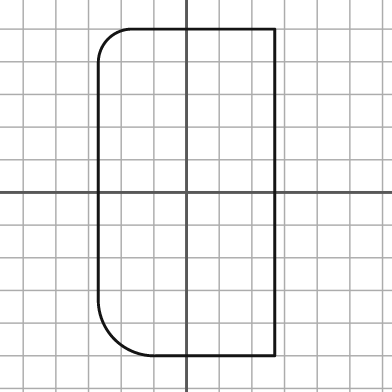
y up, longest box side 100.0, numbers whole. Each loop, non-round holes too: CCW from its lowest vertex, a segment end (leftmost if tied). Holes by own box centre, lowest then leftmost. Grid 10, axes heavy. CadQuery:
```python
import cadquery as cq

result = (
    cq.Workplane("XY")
    .moveTo(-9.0, -50.0)
    .lineTo(27.0, -50.0)
    .lineTo(27.0, 50.0)
    .lineTo(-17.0, 50.0)
    .threePointArc((-24.0, 47.0), (-27.0, 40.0))
    .lineTo(-27.0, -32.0)
    .threePointArc((-22.0, -45.0), (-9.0, -50.0))
    .close()
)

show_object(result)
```